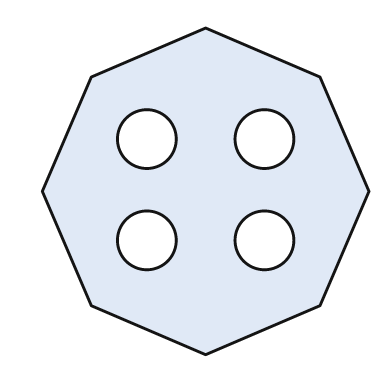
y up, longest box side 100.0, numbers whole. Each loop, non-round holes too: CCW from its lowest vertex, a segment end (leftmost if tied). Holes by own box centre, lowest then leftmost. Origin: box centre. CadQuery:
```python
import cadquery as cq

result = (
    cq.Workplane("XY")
    .moveTo(0.0, -50.0)
    .lineTo(35.0, -35.0)
    .lineTo(50.0, 0.0)
    .lineTo(35.0, 35.0)
    .lineTo(0.0, 50.0)
    .lineTo(-35.0, 35.0)
    .lineTo(-50.0, 0.0)
    .lineTo(-35.0, -35.0)
    .close()
    .moveTo(-18.0, -15.0)
    .circle(9.0)
    .moveTo(18.0, -15.0)
    .circle(9.0)
    .moveTo(-18.0, 16.0)
    .circle(9.0)
    .moveTo(18.0, 16.0)
    .circle(9.0)
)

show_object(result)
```